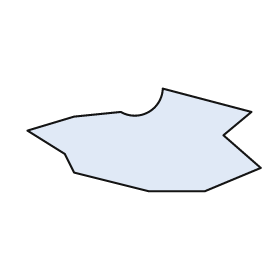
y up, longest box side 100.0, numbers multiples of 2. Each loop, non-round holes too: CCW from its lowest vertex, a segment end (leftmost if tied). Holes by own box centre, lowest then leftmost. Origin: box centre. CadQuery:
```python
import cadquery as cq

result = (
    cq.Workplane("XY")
    .moveTo(2.0, -22.0)
    .lineTo(26.0, -22.0)
    .lineTo(50.0, -12.0)
    .lineTo(34.0, 2.0)
    .lineTo(46.0, 12.0)
    .lineTo(8.0, 22.0)
    .threePointArc((2.0, 12.0), (-10.0, 12.0))
    .lineTo(-30.0, 10.0)
    .lineTo(-50.0, 4.0)
    .lineTo(-34.0, -6.0)
    .lineTo(-30.0, -14.0)
    .close()
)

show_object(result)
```